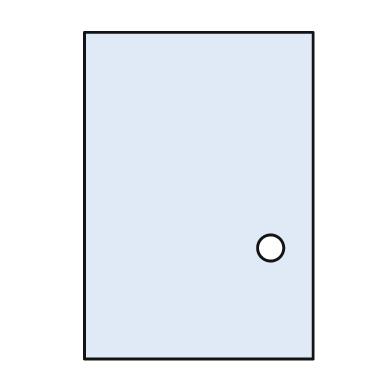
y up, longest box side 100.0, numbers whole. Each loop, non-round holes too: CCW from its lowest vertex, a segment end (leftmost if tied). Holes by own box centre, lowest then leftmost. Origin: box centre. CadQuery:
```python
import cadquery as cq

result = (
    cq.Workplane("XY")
    .moveTo(-35.0, -50.0)
    .lineTo(35.0, -50.0)
    .lineTo(35.0, 50.0)
    .lineTo(-35.0, 50.0)
    .close()
    .moveTo(22.0, -16.0)
    .circle(4.0)
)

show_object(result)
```